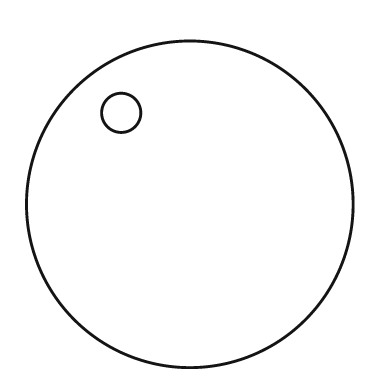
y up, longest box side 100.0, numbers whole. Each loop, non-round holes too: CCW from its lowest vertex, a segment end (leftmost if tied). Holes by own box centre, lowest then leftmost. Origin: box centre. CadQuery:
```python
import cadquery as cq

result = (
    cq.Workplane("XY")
    .moveTo(0.0, 0.0)
    .circle(50.0)
    .moveTo(-21.0, 28.0)
    .circle(6.0)
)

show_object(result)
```